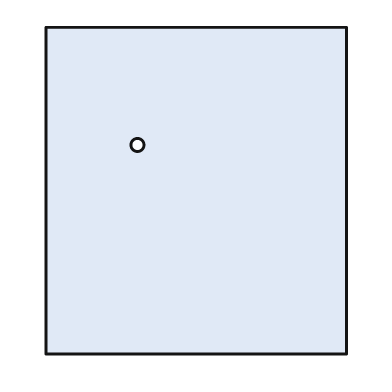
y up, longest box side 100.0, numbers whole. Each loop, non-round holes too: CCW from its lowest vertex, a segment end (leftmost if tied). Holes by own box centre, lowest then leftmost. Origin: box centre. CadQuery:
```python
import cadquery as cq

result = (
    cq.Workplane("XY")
    .moveTo(-46.0, -50.0)
    .lineTo(46.0, -50.0)
    .lineTo(46.0, 50.0)
    .lineTo(-46.0, 50.0)
    .close()
    .moveTo(-18.0, 14.0)
    .circle(2.0)
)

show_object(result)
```